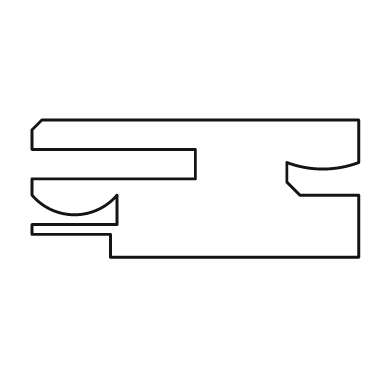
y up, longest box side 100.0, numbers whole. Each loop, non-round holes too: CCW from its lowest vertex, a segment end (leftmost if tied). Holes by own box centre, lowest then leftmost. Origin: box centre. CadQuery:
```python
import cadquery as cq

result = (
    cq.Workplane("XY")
    .moveTo(-26.0, -21.0)
    .lineTo(50.0, -21.0)
    .lineTo(50.0, -2.0)
    .lineTo(32.0, -2.0)
    .lineTo(28.0, 2.0)
    .lineTo(28.0, 8.0)
    .threePointArc((39.0, 6.0), (50.0, 8.0))
    .lineTo(50.0, 21.0)
    .lineTo(-47.0, 21.0)
    .lineTo(-50.0, 18.0)
    .lineTo(-50.0, 12.0)
    .lineTo(0.0, 12.0)
    .lineTo(0.0, 3.0)
    .lineTo(-50.0, 3.0)
    .lineTo(-50.0, -2.0)
    .threePointArc((-37.0, -8.0), (-24.0, -2.0))
    .lineTo(-24.0, -11.0)
    .lineTo(-50.0, -11.0)
    .lineTo(-50.0, -14.0)
    .lineTo(-26.0, -14.0)
    .close()
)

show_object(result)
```